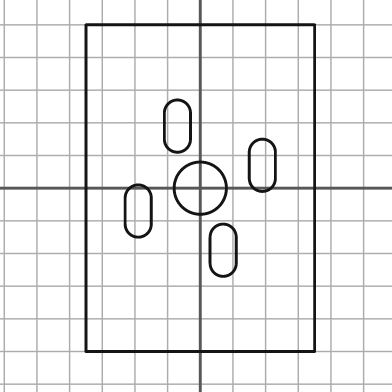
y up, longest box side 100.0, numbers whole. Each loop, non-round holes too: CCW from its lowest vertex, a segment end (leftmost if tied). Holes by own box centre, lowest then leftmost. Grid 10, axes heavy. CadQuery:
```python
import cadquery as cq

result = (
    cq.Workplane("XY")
    .moveTo(-35.0, -50.0)
    .lineTo(35.0, -50.0)
    .lineTo(35.0, 50.0)
    .lineTo(-35.0, 50.0)
    .close()
    .moveTo(3.0, -23.0)
    .threePointArc((7.0, -27.0), (11.0, -23.0))
    .lineTo(11.0, -15.0)
    .threePointArc((7.0, -11.0), (3.0, -15.0))
    .close()
    .moveTo(-23.0, -11.0)
    .threePointArc((-19.0, -15.0), (-15.0, -11.0))
    .lineTo(-15.0, -3.0)
    .threePointArc((-19.0, 1.0), (-23.0, -3.0))
    .close()
    .moveTo(0.0, 0.0)
    .circle(8.0)
    .moveTo(15.0, 3.0)
    .threePointArc((19.0, -1.0), (23.0, 3.0))
    .lineTo(23.0, 11.0)
    .threePointArc((19.0, 15.0), (15.0, 11.0))
    .close()
    .moveTo(-11.0, 15.0)
    .threePointArc((-7.0, 11.0), (-3.0, 15.0))
    .lineTo(-3.0, 23.0)
    .threePointArc((-7.0, 27.0), (-11.0, 23.0))
    .close()
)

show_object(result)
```